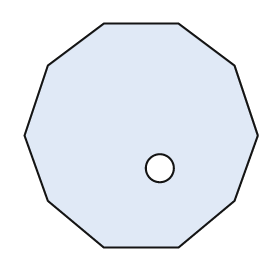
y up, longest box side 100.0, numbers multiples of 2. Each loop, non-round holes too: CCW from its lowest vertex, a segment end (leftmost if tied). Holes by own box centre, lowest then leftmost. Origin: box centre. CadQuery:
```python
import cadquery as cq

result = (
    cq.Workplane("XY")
    .moveTo(-16.0, -48.0)
    .lineTo(16.0, -48.0)
    .lineTo(40.0, -28.0)
    .lineTo(50.0, 0.0)
    .lineTo(40.0, 30.0)
    .lineTo(16.0, 48.0)
    .lineTo(-16.0, 48.0)
    .lineTo(-40.0, 30.0)
    .lineTo(-50.0, 0.0)
    .lineTo(-40.0, -28.0)
    .close()
    .moveTo(8.0, -14.0)
    .circle(6.0)
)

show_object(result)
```